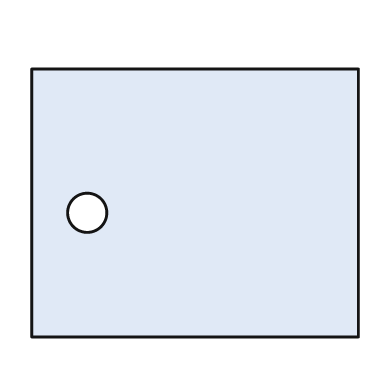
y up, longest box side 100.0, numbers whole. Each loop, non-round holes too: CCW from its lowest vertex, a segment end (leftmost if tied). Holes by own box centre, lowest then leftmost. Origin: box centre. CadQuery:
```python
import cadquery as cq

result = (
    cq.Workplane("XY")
    .moveTo(-50.0, -41.0)
    .lineTo(50.0, -41.0)
    .lineTo(50.0, 41.0)
    .lineTo(-50.0, 41.0)
    .close()
    .moveTo(-33.0, -3.0)
    .circle(6.0)
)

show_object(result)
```